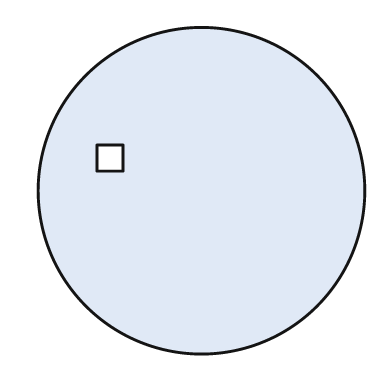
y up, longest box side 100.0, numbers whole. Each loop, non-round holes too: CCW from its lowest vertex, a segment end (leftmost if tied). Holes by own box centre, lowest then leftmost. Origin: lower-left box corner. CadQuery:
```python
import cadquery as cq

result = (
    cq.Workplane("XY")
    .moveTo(50.0, 50.0)
    .circle(50.0)
    .moveTo(18.0, 56.0)
    .lineTo(26.0, 56.0)
    .lineTo(26.0, 64.0)
    .lineTo(18.0, 64.0)
    .close()
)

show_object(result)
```